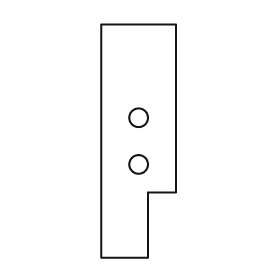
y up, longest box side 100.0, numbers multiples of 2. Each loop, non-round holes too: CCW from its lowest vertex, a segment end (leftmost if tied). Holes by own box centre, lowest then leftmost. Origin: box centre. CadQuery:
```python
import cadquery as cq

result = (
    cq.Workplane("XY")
    .moveTo(-16.0, -50.0)
    .lineTo(4.0, -50.0)
    .lineTo(4.0, -22.0)
    .lineTo(16.0, -22.0)
    .lineTo(16.0, 50.0)
    .lineTo(-16.0, 50.0)
    .close()
    .moveTo(0.0, -10.0)
    .circle(4.0)
    .moveTo(0.0, 10.0)
    .circle(4.0)
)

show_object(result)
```